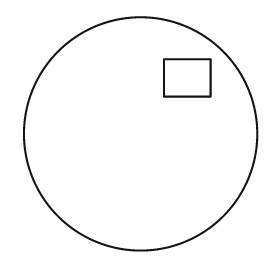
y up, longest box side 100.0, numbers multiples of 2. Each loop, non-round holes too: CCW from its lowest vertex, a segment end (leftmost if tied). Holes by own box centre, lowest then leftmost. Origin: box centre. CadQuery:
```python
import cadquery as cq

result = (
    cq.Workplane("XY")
    .moveTo(0.0, 0.0)
    .circle(50.0)
    .moveTo(10.0, 16.0)
    .lineTo(30.0, 16.0)
    .lineTo(30.0, 32.0)
    .lineTo(10.0, 32.0)
    .close()
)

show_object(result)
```